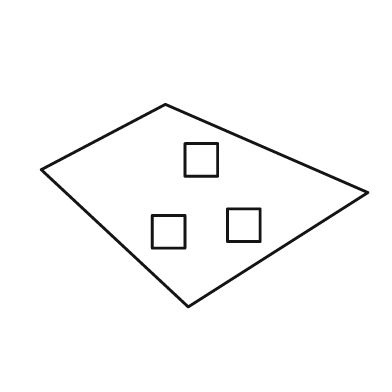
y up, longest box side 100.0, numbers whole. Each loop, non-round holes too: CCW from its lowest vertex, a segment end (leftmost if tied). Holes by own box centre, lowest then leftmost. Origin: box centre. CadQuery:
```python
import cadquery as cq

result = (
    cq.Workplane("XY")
    .moveTo(-5.0, -31.0)
    .lineTo(50.0, 4.0)
    .lineTo(-12.0, 31.0)
    .lineTo(-50.0, 11.0)
    .close()
    .moveTo(-16.0, -13.0)
    .lineTo(-6.0, -13.0)
    .lineTo(-6.0, -3.0)
    .lineTo(-16.0, -3.0)
    .close()
    .moveTo(7.0, -11.0)
    .lineTo(17.0, -11.0)
    .lineTo(17.0, -1.0)
    .lineTo(7.0, -1.0)
    .close()
    .moveTo(-6.0, 9.0)
    .lineTo(4.0, 9.0)
    .lineTo(4.0, 19.0)
    .lineTo(-6.0, 19.0)
    .close()
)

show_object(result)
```